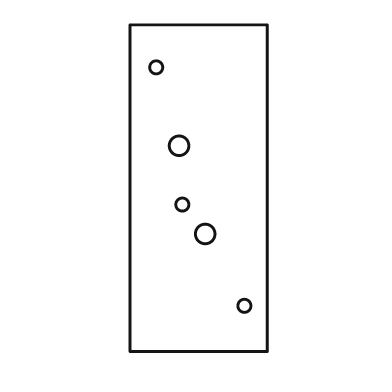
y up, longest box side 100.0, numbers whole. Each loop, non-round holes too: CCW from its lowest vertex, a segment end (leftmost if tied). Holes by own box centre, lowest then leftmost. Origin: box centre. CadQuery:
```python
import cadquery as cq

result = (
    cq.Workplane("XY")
    .moveTo(-21.0, -50.0)
    .lineTo(21.0, -50.0)
    .lineTo(21.0, 50.0)
    .lineTo(-21.0, 50.0)
    .close()
    .moveTo(14.0, -36.0)
    .circle(2.0)
    .moveTo(2.0, -14.0)
    .circle(3.0)
    .moveTo(-5.0, -5.0)
    .circle(2.0)
    .moveTo(-6.0, 13.0)
    .circle(3.0)
    .moveTo(-13.0, 37.0)
    .circle(2.0)
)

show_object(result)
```